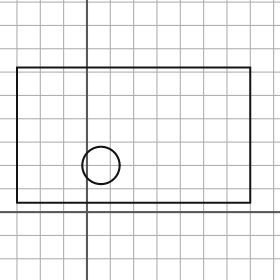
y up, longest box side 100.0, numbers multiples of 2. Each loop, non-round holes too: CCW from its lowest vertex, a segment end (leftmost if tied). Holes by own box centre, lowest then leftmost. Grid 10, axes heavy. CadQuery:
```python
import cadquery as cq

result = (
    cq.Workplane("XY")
    .moveTo(-30.0, 4.0)
    .lineTo(70.0, 4.0)
    .lineTo(70.0, 62.0)
    .lineTo(-30.0, 62.0)
    .close()
    .moveTo(6.0, 20.0)
    .circle(8.0)
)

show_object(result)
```